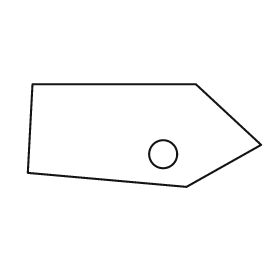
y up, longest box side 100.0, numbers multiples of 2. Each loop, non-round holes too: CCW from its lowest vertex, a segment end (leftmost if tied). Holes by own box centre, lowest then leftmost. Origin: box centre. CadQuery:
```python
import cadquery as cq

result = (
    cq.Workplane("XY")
    .moveTo(18.0, -22.0)
    .lineTo(50.0, -4.0)
    .lineTo(22.0, 22.0)
    .lineTo(-48.0, 22.0)
    .lineTo(-50.0, -16.0)
    .close()
    .moveTo(8.0, -8.0)
    .circle(6.0)
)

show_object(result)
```